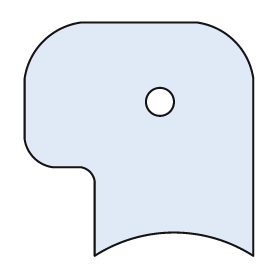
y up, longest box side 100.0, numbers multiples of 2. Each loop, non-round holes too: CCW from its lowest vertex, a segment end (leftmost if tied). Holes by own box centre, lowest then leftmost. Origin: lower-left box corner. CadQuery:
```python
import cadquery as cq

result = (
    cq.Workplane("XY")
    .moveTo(30.0, 0.0)
    .threePointArc((64.0, 10.0), (98.0, 0.0))
    .lineTo(98.0, 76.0)
    .threePointArc((90.0, 92.0), (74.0, 100.0))
    .lineTo(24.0, 100.0)
    .threePointArc((8.0, 92.0), (0.0, 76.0))
    .lineTo(0.0, 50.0)
    .threePointArc((4.0, 42.0), (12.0, 38.0))
    .lineTo(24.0, 38.0)
    .threePointArc((28.0, 36.0), (30.0, 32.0))
    .close()
    .moveTo(58.0, 66.0)
    .circle(6.0)
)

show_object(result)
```